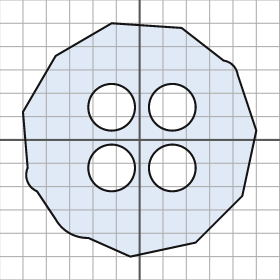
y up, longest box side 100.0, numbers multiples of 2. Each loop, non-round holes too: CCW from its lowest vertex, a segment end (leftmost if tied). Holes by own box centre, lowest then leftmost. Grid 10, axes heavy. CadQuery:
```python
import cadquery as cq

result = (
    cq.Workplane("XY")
    .moveTo(-4.0, -50.0)
    .lineTo(24.0, -44.0)
    .lineTo(44.0, -24.0)
    .lineTo(50.0, 4.0)
    .lineTo(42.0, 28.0)
    .threePointArc((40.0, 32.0), (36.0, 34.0))
    .lineTo(18.0, 48.0)
    .lineTo(-12.0, 50.0)
    .lineTo(-36.0, 36.0)
    .lineTo(-50.0, 12.0)
    .lineTo(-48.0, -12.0)
    .threePointArc((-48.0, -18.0), (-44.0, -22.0))
    .lineTo(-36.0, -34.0)
    .threePointArc((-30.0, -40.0), (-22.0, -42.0))
    .close()
    .moveTo(-12.0, -12.0)
    .circle(10.0)
    .moveTo(14.0, -12.0)
    .circle(10.0)
    .moveTo(-12.0, 14.0)
    .circle(10.0)
    .moveTo(14.0, 14.0)
    .circle(10.0)
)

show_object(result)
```